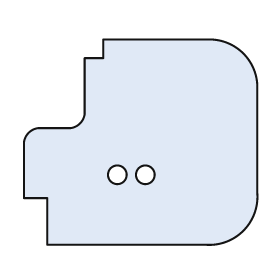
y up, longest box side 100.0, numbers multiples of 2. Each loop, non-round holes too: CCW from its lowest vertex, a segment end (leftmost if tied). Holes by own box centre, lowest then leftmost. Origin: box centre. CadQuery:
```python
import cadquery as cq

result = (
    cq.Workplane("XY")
    .moveTo(-40.0, -44.0)
    .lineTo(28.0, -44.0)
    .threePointArc((44.0, -38.0), (50.0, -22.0))
    .lineTo(50.0, 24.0)
    .threePointArc((44.0, 38.0), (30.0, 44.0))
    .lineTo(-16.0, 44.0)
    .lineTo(-16.0, 36.0)
    .lineTo(-24.0, 36.0)
    .lineTo(-24.0, 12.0)
    .threePointArc((-26.0, 8.0), (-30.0, 6.0))
    .lineTo(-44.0, 6.0)
    .threePointArc((-48.0, 4.0), (-50.0, 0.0))
    .lineTo(-50.0, -24.0)
    .lineTo(-40.0, -24.0)
    .close()
    .moveTo(-10.0, -14.0)
    .circle(4.0)
    .moveTo(2.0, -14.0)
    .circle(4.0)
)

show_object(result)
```